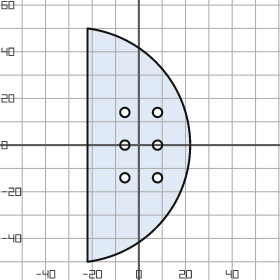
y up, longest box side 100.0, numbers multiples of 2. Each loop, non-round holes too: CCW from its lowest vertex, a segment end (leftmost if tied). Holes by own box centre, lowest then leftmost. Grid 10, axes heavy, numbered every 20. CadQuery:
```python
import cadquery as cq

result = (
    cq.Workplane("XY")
    .moveTo(-22.0, -50.0)
    .threePointArc((22.0, 0.0), (-22.0, 50.0))
    .close()
    .moveTo(-6.0, -14.0)
    .circle(2.0)
    .moveTo(8.0, -14.0)
    .circle(2.0)
    .moveTo(-6.0, 0.0)
    .circle(2.0)
    .moveTo(8.0, 0.0)
    .circle(2.0)
    .moveTo(-6.0, 14.0)
    .circle(2.0)
    .moveTo(8.0, 14.0)
    .circle(2.0)
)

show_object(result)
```